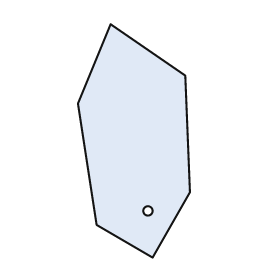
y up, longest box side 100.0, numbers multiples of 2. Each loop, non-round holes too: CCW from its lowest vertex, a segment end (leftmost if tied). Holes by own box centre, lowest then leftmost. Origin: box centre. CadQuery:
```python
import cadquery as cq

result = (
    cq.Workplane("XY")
    .moveTo(8.0, -50.0)
    .lineTo(24.0, -22.0)
    .lineTo(22.0, 28.0)
    .lineTo(-10.0, 50.0)
    .lineTo(-24.0, 16.0)
    .lineTo(-16.0, -36.0)
    .close()
    .moveTo(6.0, -30.0)
    .circle(2.0)
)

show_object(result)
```